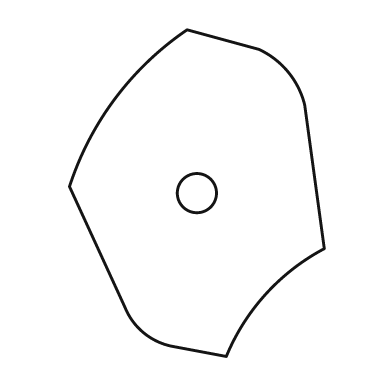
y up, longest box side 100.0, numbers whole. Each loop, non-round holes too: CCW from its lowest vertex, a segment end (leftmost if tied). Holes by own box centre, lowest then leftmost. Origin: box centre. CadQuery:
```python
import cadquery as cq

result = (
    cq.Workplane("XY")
    .moveTo(9.0, -50.0)
    .threePointArc((21.0, -31.0), (39.0, -17.0))
    .lineTo(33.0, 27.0)
    .threePointArc((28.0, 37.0), (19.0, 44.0))
    .lineTo(-3.0, 50.0)
    .threePointArc((-25.0, 29.0), (-39.0, 2.0))
    .lineTo(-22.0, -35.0)
    .threePointArc((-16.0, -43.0), (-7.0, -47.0))
    .close()
    .moveTo(0.0, 0.0)
    .circle(6.0)
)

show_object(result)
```